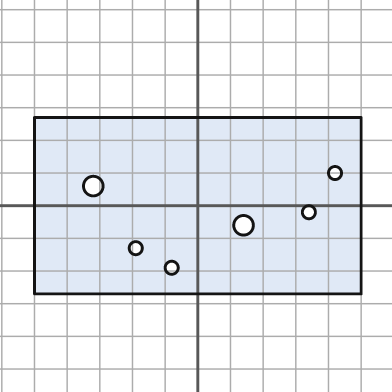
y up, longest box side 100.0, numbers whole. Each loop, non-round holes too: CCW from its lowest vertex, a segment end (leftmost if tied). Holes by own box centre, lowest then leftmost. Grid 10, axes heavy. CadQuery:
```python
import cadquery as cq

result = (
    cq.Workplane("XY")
    .moveTo(-50.0, -27.0)
    .lineTo(50.0, -27.0)
    .lineTo(50.0, 27.0)
    .lineTo(-50.0, 27.0)
    .close()
    .moveTo(-8.0, -19.0)
    .circle(2.0)
    .moveTo(-19.0, -13.0)
    .circle(2.0)
    .moveTo(14.0, -6.0)
    .circle(3.0)
    .moveTo(34.0, -2.0)
    .circle(2.0)
    .moveTo(-32.0, 6.0)
    .circle(3.0)
    .moveTo(42.0, 10.0)
    .circle(2.0)
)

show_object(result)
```